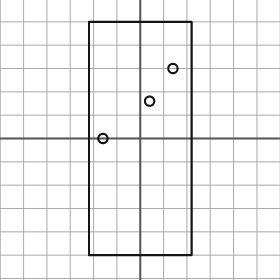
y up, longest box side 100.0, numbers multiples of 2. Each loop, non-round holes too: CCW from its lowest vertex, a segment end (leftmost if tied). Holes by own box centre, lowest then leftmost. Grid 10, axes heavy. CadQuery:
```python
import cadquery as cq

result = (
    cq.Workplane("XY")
    .moveTo(-22.0, -50.0)
    .lineTo(22.0, -50.0)
    .lineTo(22.0, 50.0)
    .lineTo(-22.0, 50.0)
    .close()
    .moveTo(-16.0, 0.0)
    .circle(2.0)
    .moveTo(4.0, 16.0)
    .circle(2.0)
    .moveTo(14.0, 30.0)
    .circle(2.0)
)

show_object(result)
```